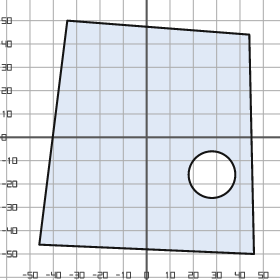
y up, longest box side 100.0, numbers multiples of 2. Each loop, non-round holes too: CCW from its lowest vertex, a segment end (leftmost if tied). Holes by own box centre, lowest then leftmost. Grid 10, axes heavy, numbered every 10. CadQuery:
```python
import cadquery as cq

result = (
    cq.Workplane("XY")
    .moveTo(46.0, -50.0)
    .lineTo(44.0, 44.0)
    .lineTo(-34.0, 50.0)
    .lineTo(-46.0, -46.0)
    .close()
    .moveTo(28.0, -16.0)
    .circle(10.0)
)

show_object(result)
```